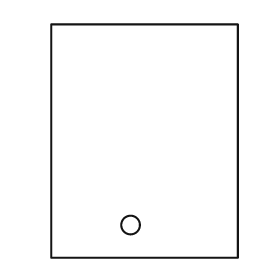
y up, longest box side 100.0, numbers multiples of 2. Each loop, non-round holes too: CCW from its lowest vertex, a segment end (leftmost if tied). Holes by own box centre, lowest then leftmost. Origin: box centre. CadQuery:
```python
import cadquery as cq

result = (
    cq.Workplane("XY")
    .moveTo(-40.0, -50.0)
    .lineTo(40.0, -50.0)
    .lineTo(40.0, 50.0)
    .lineTo(-40.0, 50.0)
    .close()
    .moveTo(-6.0, -36.0)
    .circle(4.0)
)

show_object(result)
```